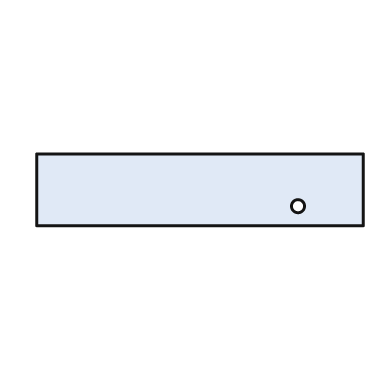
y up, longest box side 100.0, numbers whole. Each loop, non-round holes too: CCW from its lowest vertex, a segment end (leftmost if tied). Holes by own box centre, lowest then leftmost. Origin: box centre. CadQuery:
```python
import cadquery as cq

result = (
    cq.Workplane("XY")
    .moveTo(-50.0, -11.0)
    .lineTo(50.0, -11.0)
    .lineTo(50.0, 11.0)
    .lineTo(-50.0, 11.0)
    .close()
    .moveTo(30.0, -5.0)
    .circle(2.0)
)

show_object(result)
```